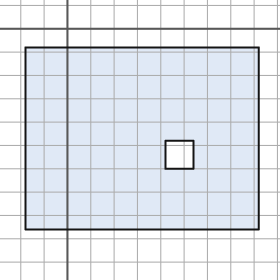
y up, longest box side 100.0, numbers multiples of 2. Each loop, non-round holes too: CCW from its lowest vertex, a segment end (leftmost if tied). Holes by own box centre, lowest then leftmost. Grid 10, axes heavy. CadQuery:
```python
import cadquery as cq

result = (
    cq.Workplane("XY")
    .moveTo(-18.0, -86.0)
    .lineTo(82.0, -86.0)
    .lineTo(82.0, -8.0)
    .lineTo(-18.0, -8.0)
    .close()
    .moveTo(42.0, -60.0)
    .lineTo(54.0, -60.0)
    .lineTo(54.0, -48.0)
    .lineTo(42.0, -48.0)
    .close()
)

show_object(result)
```